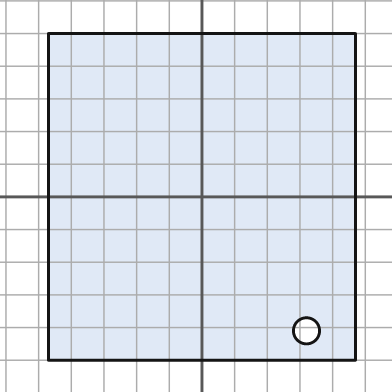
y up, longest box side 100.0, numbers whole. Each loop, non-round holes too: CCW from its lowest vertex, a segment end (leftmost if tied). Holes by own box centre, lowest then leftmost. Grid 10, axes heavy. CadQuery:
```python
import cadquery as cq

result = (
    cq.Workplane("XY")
    .moveTo(-47.0, -50.0)
    .lineTo(47.0, -50.0)
    .lineTo(47.0, 50.0)
    .lineTo(-47.0, 50.0)
    .close()
    .moveTo(32.0, -41.0)
    .circle(4.0)
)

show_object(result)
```